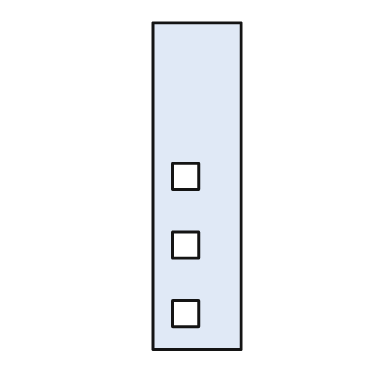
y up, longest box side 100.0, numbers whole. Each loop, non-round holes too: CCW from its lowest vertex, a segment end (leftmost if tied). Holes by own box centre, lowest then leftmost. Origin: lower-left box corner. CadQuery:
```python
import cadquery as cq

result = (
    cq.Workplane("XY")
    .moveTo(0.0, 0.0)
    .lineTo(27.0, 0.0)
    .lineTo(27.0, 100.0)
    .lineTo(0.0, 100.0)
    .close()
    .moveTo(6.0, 7.0)
    .lineTo(14.0, 7.0)
    .lineTo(14.0, 15.0)
    .lineTo(6.0, 15.0)
    .close()
    .moveTo(6.0, 28.0)
    .lineTo(14.0, 28.0)
    .lineTo(14.0, 36.0)
    .lineTo(6.0, 36.0)
    .close()
    .moveTo(6.0, 49.0)
    .lineTo(14.0, 49.0)
    .lineTo(14.0, 57.0)
    .lineTo(6.0, 57.0)
    .close()
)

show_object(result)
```